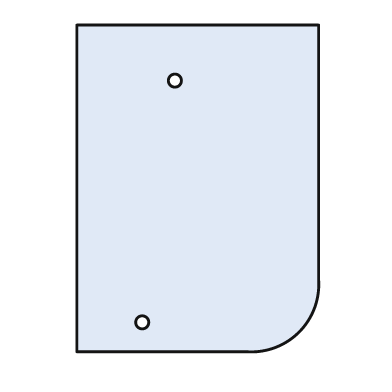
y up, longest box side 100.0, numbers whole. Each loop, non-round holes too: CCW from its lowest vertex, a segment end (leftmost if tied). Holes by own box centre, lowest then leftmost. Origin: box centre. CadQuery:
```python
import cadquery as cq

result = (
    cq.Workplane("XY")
    .moveTo(-37.0, -50.0)
    .lineTo(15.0, -50.0)
    .threePointArc((31.0, -44.0), (37.0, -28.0))
    .lineTo(37.0, 50.0)
    .lineTo(-37.0, 50.0)
    .close()
    .moveTo(-17.0, -41.0)
    .circle(2.0)
    .moveTo(-7.0, 33.0)
    .circle(2.0)
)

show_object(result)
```